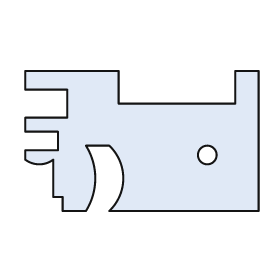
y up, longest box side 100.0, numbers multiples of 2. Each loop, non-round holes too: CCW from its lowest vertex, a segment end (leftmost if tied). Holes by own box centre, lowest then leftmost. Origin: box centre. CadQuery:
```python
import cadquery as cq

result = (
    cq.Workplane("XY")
    .moveTo(-34.0, -30.0)
    .lineTo(-24.0, -30.0)
    .threePointArc((-20.0, -16.0), (-24.0, -2.0))
    .lineTo(-14.0, -2.0)
    .threePointArc((-8.0, -16.0), (-14.0, -30.0))
    .lineTo(50.0, -30.0)
    .lineTo(50.0, 30.0)
    .lineTo(40.0, 30.0)
    .lineTo(40.0, 16.0)
    .lineTo(-10.0, 16.0)
    .lineTo(-10.0, 30.0)
    .lineTo(-50.0, 30.0)
    .lineTo(-50.0, 22.0)
    .lineTo(-32.0, 22.0)
    .lineTo(-32.0, 10.0)
    .lineTo(-50.0, 10.0)
    .lineTo(-50.0, 4.0)
    .lineTo(-36.0, 4.0)
    .lineTo(-36.0, -4.0)
    .lineTo(-50.0, -4.0)
    .lineTo(-50.0, -8.0)
    .threePointArc((-44.0, -10.0), (-38.0, -8.0))
    .lineTo(-38.0, -24.0)
    .lineTo(-34.0, -24.0)
    .close()
    .moveTo(28.0, -6.0)
    .circle(4.0)
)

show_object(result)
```